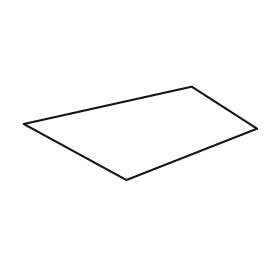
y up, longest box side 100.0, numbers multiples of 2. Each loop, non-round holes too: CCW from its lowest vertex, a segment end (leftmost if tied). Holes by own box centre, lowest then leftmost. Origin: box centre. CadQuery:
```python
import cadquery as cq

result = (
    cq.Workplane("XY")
    .moveTo(-6.0, -20.0)
    .lineTo(50.0, 2.0)
    .lineTo(22.0, 20.0)
    .lineTo(-50.0, 4.0)
    .close()
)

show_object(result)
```